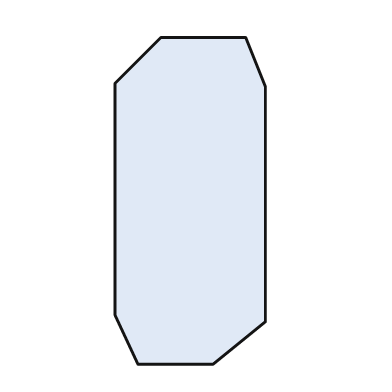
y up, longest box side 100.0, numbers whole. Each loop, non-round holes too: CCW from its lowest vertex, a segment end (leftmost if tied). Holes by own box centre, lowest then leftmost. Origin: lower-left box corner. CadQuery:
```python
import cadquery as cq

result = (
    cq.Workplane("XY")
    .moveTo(7.0, 0.0)
    .lineTo(30.0, 0.0)
    .lineTo(46.0, 13.0)
    .lineTo(46.0, 85.0)
    .lineTo(40.0, 100.0)
    .lineTo(14.0, 100.0)
    .lineTo(0.0, 86.0)
    .lineTo(0.0, 15.0)
    .close()
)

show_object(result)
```